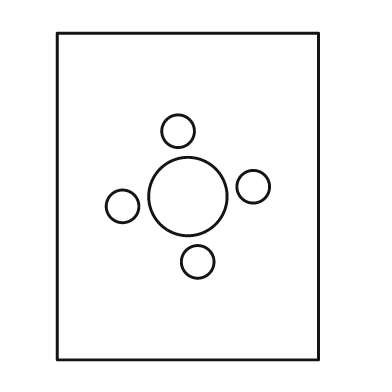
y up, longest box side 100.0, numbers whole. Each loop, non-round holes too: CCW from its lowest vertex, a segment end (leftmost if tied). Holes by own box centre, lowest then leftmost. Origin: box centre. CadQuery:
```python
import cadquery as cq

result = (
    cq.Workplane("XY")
    .moveTo(-40.0, -50.0)
    .lineTo(40.0, -50.0)
    .lineTo(40.0, 50.0)
    .lineTo(-40.0, 50.0)
    .close()
    .moveTo(3.0, -20.0)
    .circle(5.0)
    .moveTo(-20.0, -3.0)
    .circle(5.0)
    .moveTo(0.0, 0.0)
    .circle(12.0)
    .moveTo(20.0, 3.0)
    .circle(5.0)
    .moveTo(-3.0, 20.0)
    .circle(5.0)
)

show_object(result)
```